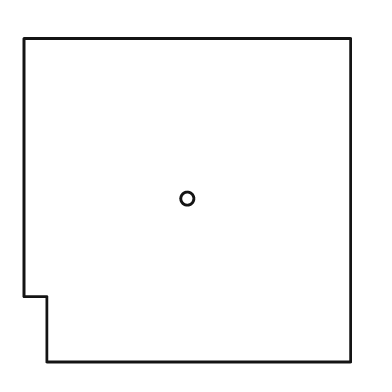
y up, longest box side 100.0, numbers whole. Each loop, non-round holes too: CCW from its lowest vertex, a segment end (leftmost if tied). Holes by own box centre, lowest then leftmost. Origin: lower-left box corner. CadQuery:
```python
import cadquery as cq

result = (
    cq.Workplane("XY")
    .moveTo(7.0, 0.0)
    .lineTo(100.0, 0.0)
    .lineTo(100.0, 99.0)
    .lineTo(0.0, 99.0)
    .lineTo(0.0, 20.0)
    .lineTo(7.0, 20.0)
    .close()
    .moveTo(50.0, 50.0)
    .circle(2.0)
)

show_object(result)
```